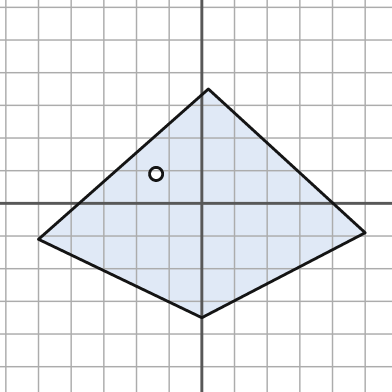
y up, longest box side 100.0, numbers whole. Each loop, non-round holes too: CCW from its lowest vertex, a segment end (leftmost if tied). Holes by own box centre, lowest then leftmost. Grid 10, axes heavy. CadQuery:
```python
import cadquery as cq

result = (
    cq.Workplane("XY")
    .moveTo(0.0, -35.0)
    .lineTo(50.0, -9.0)
    .lineTo(2.0, 35.0)
    .lineTo(-50.0, -11.0)
    .close()
    .moveTo(-14.0, 9.0)
    .circle(2.0)
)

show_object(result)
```